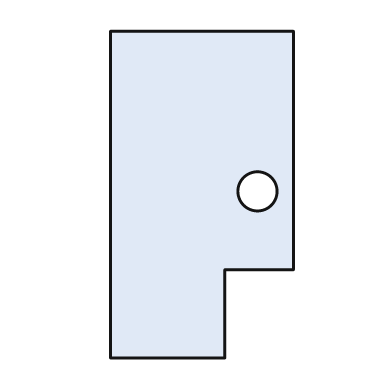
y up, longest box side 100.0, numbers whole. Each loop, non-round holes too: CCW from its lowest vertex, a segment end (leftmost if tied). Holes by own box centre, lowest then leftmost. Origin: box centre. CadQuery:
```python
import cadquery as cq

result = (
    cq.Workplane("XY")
    .moveTo(-28.0, -50.0)
    .lineTo(7.0, -50.0)
    .lineTo(7.0, -23.0)
    .lineTo(28.0, -23.0)
    .lineTo(28.0, 50.0)
    .lineTo(-28.0, 50.0)
    .close()
    .moveTo(17.0, 1.0)
    .circle(6.0)
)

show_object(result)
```